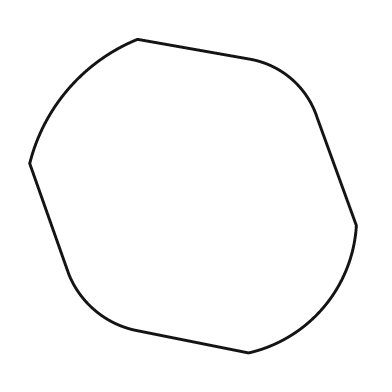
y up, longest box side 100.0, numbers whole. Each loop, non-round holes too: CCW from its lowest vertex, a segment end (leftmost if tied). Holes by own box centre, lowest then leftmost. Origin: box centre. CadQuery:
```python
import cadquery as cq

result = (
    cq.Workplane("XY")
    .moveTo(17.0, -48.0)
    .threePointArc((40.0, -34.0), (50.0, -9.0))
    .lineTo(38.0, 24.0)
    .threePointArc((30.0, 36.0), (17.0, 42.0))
    .lineTo(-17.0, 48.0)
    .threePointArc((-38.0, 33.0), (-50.0, 10.0))
    .lineTo(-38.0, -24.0)
    .threePointArc((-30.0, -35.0), (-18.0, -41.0))
    .close()
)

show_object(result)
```